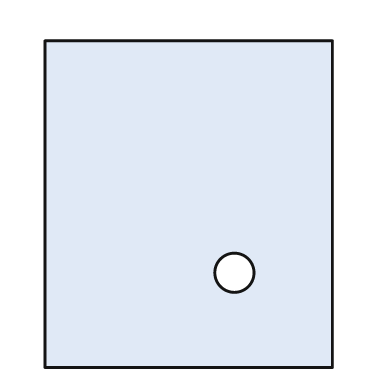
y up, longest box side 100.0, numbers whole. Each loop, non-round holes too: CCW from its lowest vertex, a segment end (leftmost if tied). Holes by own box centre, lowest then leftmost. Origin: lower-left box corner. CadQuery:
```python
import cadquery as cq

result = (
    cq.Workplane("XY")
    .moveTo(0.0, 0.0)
    .lineTo(88.0, 0.0)
    .lineTo(88.0, 100.0)
    .lineTo(0.0, 100.0)
    .close()
    .moveTo(58.0, 29.0)
    .circle(6.0)
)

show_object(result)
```